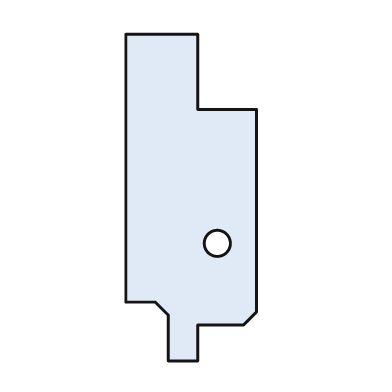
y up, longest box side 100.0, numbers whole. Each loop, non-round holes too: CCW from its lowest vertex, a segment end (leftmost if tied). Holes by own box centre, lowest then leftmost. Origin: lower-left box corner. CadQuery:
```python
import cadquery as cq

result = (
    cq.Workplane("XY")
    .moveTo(13.0, 0.0)
    .lineTo(22.0, 0.0)
    .lineTo(22.0, 11.0)
    .lineTo(36.0, 11.0)
    .lineTo(40.0, 15.0)
    .lineTo(40.0, 77.0)
    .lineTo(22.0, 77.0)
    .lineTo(22.0, 100.0)
    .lineTo(0.0, 100.0)
    .lineTo(0.0, 18.0)
    .lineTo(9.0, 18.0)
    .lineTo(13.0, 14.0)
    .close()
    .moveTo(28.0, 36.0)
    .circle(4.0)
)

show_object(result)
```